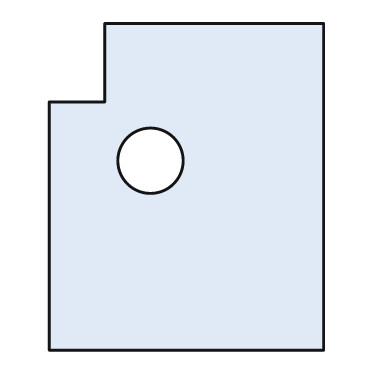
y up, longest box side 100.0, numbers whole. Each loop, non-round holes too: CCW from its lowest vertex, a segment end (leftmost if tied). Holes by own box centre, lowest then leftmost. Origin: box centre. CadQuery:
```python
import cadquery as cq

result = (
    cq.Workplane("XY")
    .moveTo(-42.0, -50.0)
    .lineTo(42.0, -50.0)
    .lineTo(42.0, 50.0)
    .lineTo(-25.0, 50.0)
    .lineTo(-25.0, 26.0)
    .lineTo(-42.0, 26.0)
    .close()
    .moveTo(-11.0, 8.0)
    .circle(10.0)
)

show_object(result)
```